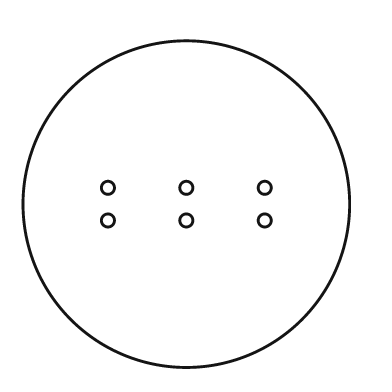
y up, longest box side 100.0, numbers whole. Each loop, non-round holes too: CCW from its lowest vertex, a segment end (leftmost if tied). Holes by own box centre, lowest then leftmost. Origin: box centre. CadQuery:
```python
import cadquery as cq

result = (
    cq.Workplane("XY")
    .moveTo(0.0, 0.0)
    .circle(50.0)
    .moveTo(-24.0, -5.0)
    .circle(2.0)
    .moveTo(0.0, -5.0)
    .circle(2.0)
    .moveTo(24.0, -5.0)
    .circle(2.0)
    .moveTo(-24.0, 5.0)
    .circle(2.0)
    .moveTo(0.0, 5.0)
    .circle(2.0)
    .moveTo(24.0, 5.0)
    .circle(2.0)
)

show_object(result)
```